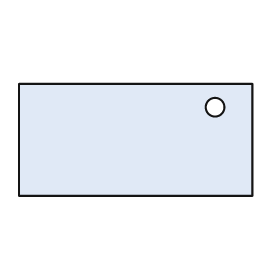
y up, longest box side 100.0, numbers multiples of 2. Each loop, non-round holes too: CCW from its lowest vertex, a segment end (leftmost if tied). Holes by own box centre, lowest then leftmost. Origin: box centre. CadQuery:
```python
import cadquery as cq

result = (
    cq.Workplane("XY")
    .moveTo(-50.0, -24.0)
    .lineTo(50.0, -24.0)
    .lineTo(50.0, 24.0)
    .lineTo(-50.0, 24.0)
    .close()
    .moveTo(34.0, 14.0)
    .circle(4.0)
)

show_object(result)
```